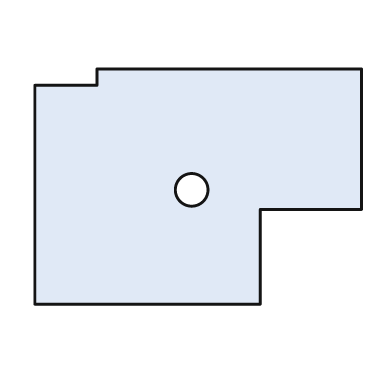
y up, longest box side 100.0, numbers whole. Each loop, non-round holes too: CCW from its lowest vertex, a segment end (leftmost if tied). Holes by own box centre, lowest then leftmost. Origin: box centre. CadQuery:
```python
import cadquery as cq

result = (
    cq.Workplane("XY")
    .moveTo(-50.0, -36.0)
    .lineTo(19.0, -36.0)
    .lineTo(19.0, -7.0)
    .lineTo(50.0, -7.0)
    .lineTo(50.0, 36.0)
    .lineTo(-31.0, 36.0)
    .lineTo(-31.0, 31.0)
    .lineTo(-50.0, 31.0)
    .close()
    .moveTo(-2.0, -1.0)
    .circle(5.0)
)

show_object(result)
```